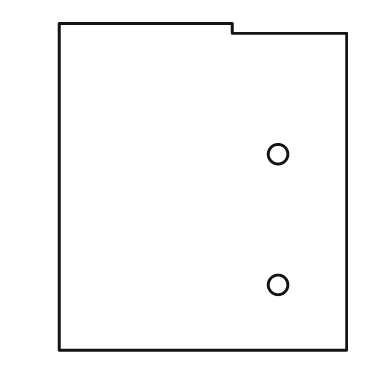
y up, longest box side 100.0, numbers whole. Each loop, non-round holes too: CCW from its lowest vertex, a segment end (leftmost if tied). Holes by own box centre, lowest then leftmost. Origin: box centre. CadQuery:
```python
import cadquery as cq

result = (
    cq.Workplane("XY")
    .moveTo(-44.0, -50.0)
    .lineTo(44.0, -50.0)
    .lineTo(44.0, 47.0)
    .lineTo(9.0, 47.0)
    .lineTo(9.0, 50.0)
    .lineTo(-44.0, 50.0)
    .close()
    .moveTo(23.0, -30.0)
    .circle(3.0)
    .moveTo(23.0, 10.0)
    .circle(3.0)
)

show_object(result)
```